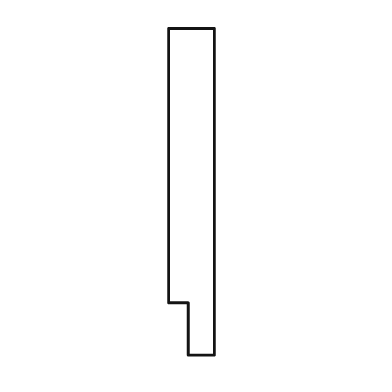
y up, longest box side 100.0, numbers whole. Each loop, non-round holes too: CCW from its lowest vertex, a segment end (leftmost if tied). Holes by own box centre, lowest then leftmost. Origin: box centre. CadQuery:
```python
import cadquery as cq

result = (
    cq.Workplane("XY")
    .moveTo(-1.0, -50.0)
    .lineTo(7.0, -50.0)
    .lineTo(7.0, 50.0)
    .lineTo(-7.0, 50.0)
    .lineTo(-7.0, -34.0)
    .lineTo(-1.0, -34.0)
    .close()
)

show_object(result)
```